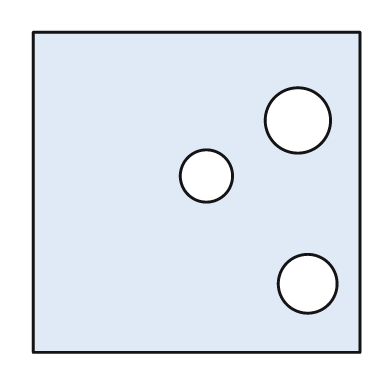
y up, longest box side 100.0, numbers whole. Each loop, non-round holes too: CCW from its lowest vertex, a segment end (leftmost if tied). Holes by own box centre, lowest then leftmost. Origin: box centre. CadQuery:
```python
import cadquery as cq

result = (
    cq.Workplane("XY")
    .moveTo(-50.0, -49.0)
    .lineTo(50.0, -49.0)
    .lineTo(50.0, 49.0)
    .lineTo(-50.0, 49.0)
    .close()
    .moveTo(34.0, -28.0)
    .circle(9.0)
    .moveTo(3.0, 5.0)
    .circle(8.0)
    .moveTo(31.0, 22.0)
    .circle(10.0)
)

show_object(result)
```